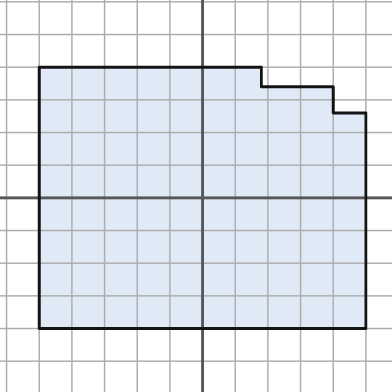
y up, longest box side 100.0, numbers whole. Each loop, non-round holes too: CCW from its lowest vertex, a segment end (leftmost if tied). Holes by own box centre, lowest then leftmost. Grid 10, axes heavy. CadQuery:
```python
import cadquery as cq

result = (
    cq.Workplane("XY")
    .moveTo(-50.0, -40.0)
    .lineTo(50.0, -40.0)
    .lineTo(50.0, 26.0)
    .lineTo(40.0, 26.0)
    .lineTo(40.0, 34.0)
    .lineTo(18.0, 34.0)
    .lineTo(18.0, 40.0)
    .lineTo(-50.0, 40.0)
    .close()
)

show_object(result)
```